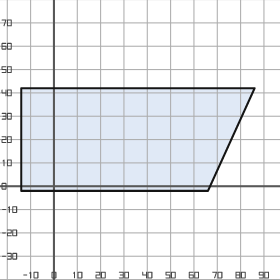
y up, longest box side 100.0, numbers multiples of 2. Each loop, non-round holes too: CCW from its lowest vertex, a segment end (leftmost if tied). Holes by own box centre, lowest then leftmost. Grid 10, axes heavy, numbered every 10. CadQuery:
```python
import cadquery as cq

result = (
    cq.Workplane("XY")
    .moveTo(-14.0, -2.0)
    .lineTo(66.0, -2.0)
    .lineTo(86.0, 42.0)
    .lineTo(-14.0, 42.0)
    .close()
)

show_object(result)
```